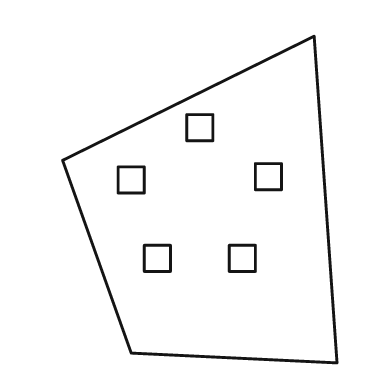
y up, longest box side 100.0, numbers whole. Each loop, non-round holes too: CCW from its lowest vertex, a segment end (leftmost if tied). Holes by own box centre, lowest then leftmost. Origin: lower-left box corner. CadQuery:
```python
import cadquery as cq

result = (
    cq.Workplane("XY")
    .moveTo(84.0, 0.0)
    .lineTo(77.0, 100.0)
    .lineTo(0.0, 62.0)
    .lineTo(21.0, 3.0)
    .close()
    .moveTo(25.0, 28.0)
    .lineTo(33.0, 28.0)
    .lineTo(33.0, 36.0)
    .lineTo(25.0, 36.0)
    .close()
    .moveTo(51.0, 28.0)
    .lineTo(59.0, 28.0)
    .lineTo(59.0, 36.0)
    .lineTo(51.0, 36.0)
    .close()
    .moveTo(17.0, 52.0)
    .lineTo(25.0, 52.0)
    .lineTo(25.0, 60.0)
    .lineTo(17.0, 60.0)
    .close()
    .moveTo(59.0, 53.0)
    .lineTo(67.0, 53.0)
    .lineTo(67.0, 61.0)
    .lineTo(59.0, 61.0)
    .close()
    .moveTo(38.0, 68.0)
    .lineTo(46.0, 68.0)
    .lineTo(46.0, 76.0)
    .lineTo(38.0, 76.0)
    .close()
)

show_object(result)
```